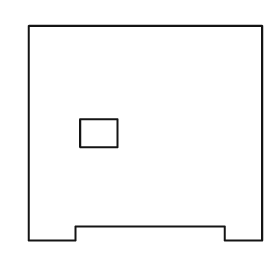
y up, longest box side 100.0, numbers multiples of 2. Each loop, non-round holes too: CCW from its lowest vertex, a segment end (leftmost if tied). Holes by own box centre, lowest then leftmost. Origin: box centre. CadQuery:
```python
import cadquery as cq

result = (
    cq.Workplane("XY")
    .moveTo(-50.0, -46.0)
    .lineTo(-30.0, -46.0)
    .lineTo(-30.0, -40.0)
    .lineTo(34.0, -40.0)
    .lineTo(34.0, -46.0)
    .lineTo(50.0, -46.0)
    .lineTo(50.0, 46.0)
    .lineTo(-50.0, 46.0)
    .close()
    .moveTo(-28.0, -6.0)
    .lineTo(-12.0, -6.0)
    .lineTo(-12.0, 6.0)
    .lineTo(-28.0, 6.0)
    .close()
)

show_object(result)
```